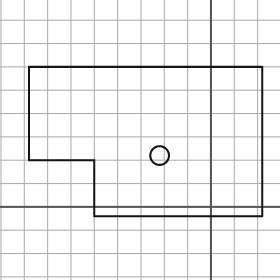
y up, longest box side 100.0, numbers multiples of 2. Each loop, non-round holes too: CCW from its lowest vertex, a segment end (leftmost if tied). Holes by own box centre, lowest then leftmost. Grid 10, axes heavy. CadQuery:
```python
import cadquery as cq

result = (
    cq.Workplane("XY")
    .moveTo(-50.0, -4.0)
    .lineTo(22.0, -4.0)
    .lineTo(22.0, 60.0)
    .lineTo(-78.0, 60.0)
    .lineTo(-78.0, 20.0)
    .lineTo(-50.0, 20.0)
    .close()
    .moveTo(-22.0, 22.0)
    .circle(4.0)
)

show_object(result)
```